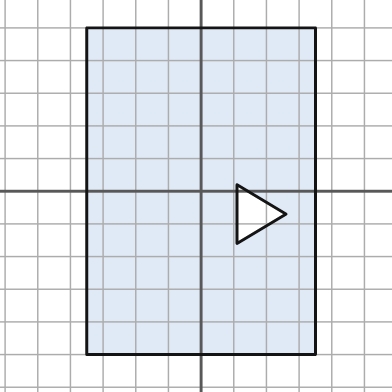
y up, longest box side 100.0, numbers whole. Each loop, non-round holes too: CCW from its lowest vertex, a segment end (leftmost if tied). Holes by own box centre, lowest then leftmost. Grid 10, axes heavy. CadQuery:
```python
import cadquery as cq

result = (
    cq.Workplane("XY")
    .moveTo(-35.0, -50.0)
    .lineTo(35.0, -50.0)
    .lineTo(35.0, 50.0)
    .lineTo(-35.0, 50.0)
    .close()
    .moveTo(11.0, -16.0)
    .lineTo(26.0, -7.0)
    .lineTo(11.0, 2.0)
    .close()
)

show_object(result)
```